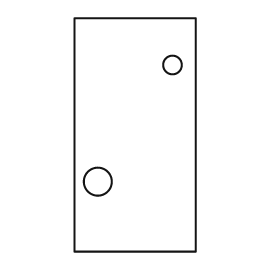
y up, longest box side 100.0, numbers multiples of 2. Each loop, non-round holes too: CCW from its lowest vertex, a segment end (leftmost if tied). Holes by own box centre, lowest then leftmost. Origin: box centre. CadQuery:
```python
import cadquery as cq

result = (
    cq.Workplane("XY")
    .moveTo(-26.0, -50.0)
    .lineTo(26.0, -50.0)
    .lineTo(26.0, 50.0)
    .lineTo(-26.0, 50.0)
    .close()
    .moveTo(-16.0, -20.0)
    .circle(6.0)
    .moveTo(16.0, 30.0)
    .circle(4.0)
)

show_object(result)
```